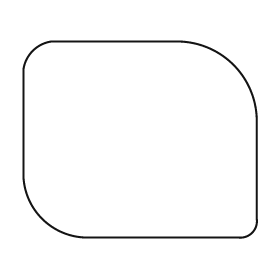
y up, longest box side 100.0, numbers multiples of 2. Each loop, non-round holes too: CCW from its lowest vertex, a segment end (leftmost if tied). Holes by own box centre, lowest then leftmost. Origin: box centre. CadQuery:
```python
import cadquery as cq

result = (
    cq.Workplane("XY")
    .moveTo(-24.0, -42.0)
    .lineTo(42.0, -42.0)
    .threePointArc((48.0, -40.0), (50.0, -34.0))
    .lineTo(50.0, 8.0)
    .threePointArc((40.0, 32.0), (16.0, 42.0))
    .lineTo(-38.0, 42.0)
    .threePointArc((-46.0, 38.0), (-50.0, 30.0))
    .lineTo(-50.0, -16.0)
    .threePointArc((-42.0, -34.0), (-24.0, -42.0))
    .close()
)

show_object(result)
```